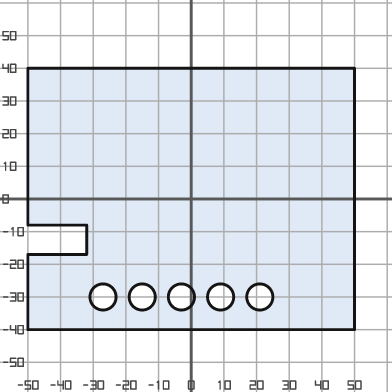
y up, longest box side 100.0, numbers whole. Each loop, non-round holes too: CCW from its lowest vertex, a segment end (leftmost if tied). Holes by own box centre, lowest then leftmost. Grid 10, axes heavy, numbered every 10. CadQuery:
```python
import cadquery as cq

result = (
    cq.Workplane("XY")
    .moveTo(-50.0, -40.0)
    .lineTo(50.0, -40.0)
    .lineTo(50.0, 40.0)
    .lineTo(-50.0, 40.0)
    .lineTo(-50.0, -8.0)
    .lineTo(-32.0, -8.0)
    .lineTo(-32.0, -17.0)
    .lineTo(-50.0, -17.0)
    .close()
    .moveTo(-27.0, -30.0)
    .circle(4.0)
    .moveTo(-15.0, -30.0)
    .circle(4.0)
    .moveTo(-3.0, -30.0)
    .circle(4.0)
    .moveTo(9.0, -30.0)
    .circle(4.0)
    .moveTo(21.0, -30.0)
    .circle(4.0)
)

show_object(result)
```